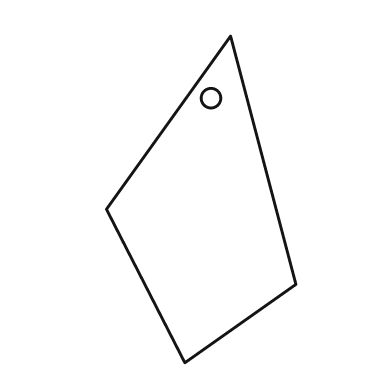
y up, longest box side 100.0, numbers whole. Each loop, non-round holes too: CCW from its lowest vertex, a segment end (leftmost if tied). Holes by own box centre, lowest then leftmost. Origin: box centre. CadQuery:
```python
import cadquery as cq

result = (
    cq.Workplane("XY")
    .moveTo(-5.0, -50.0)
    .lineTo(29.0, -26.0)
    .lineTo(9.0, 50.0)
    .lineTo(-29.0, -3.0)
    .close()
    .moveTo(3.0, 31.0)
    .circle(3.0)
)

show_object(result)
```